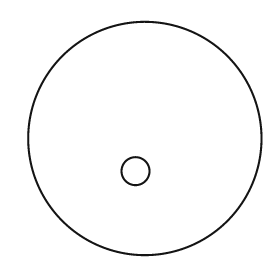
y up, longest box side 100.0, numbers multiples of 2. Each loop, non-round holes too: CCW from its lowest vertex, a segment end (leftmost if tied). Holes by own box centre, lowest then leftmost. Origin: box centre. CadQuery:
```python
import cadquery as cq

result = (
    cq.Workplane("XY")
    .moveTo(0.0, 0.0)
    .circle(50.0)
    .moveTo(-4.0, -14.0)
    .circle(6.0)
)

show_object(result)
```